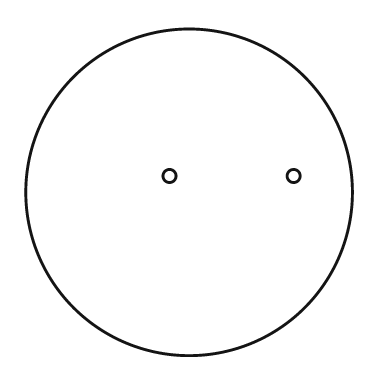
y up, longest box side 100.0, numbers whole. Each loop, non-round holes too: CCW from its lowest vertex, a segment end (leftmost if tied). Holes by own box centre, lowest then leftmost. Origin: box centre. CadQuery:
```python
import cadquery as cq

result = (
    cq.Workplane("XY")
    .moveTo(0.0, 0.0)
    .circle(50.0)
    .moveTo(-6.0, 5.0)
    .circle(2.0)
    .moveTo(32.0, 5.0)
    .circle(2.0)
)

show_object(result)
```